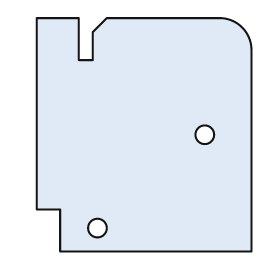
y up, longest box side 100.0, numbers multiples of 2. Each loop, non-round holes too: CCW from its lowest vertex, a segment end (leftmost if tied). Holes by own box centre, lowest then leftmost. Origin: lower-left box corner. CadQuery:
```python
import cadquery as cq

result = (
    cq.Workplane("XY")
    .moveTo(10.0, 0.0)
    .lineTo(92.0, 0.0)
    .lineTo(92.0, 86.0)
    .threePointArc((88.0, 96.0), (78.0, 100.0))
    .lineTo(30.0, 100.0)
    .lineTo(24.0, 94.0)
    .lineTo(24.0, 82.0)
    .lineTo(18.0, 82.0)
    .lineTo(18.0, 100.0)
    .lineTo(0.0, 100.0)
    .lineTo(0.0, 18.0)
    .lineTo(10.0, 18.0)
    .close()
    .moveTo(26.0, 10.0)
    .circle(4.0)
    .moveTo(72.0, 50.0)
    .circle(4.0)
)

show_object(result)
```